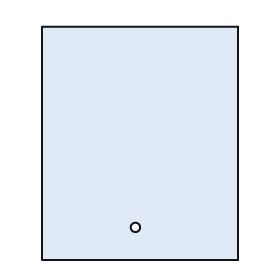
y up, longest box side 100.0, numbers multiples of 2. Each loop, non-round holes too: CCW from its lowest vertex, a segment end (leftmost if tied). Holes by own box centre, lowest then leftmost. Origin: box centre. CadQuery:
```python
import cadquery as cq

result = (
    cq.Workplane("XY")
    .moveTo(-42.0, -50.0)
    .lineTo(42.0, -50.0)
    .lineTo(42.0, 50.0)
    .lineTo(-42.0, 50.0)
    .close()
    .moveTo(-2.0, -36.0)
    .circle(2.0)
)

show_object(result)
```